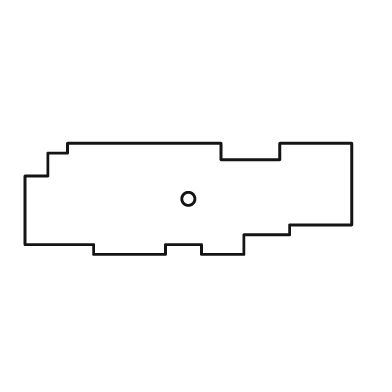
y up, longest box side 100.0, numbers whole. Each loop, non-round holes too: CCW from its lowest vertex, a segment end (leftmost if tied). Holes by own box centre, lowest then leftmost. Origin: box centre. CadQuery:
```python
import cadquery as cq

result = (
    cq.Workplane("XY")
    .moveTo(-29.0, -17.0)
    .lineTo(-7.0, -17.0)
    .lineTo(-7.0, -14.0)
    .lineTo(4.0, -14.0)
    .lineTo(4.0, -17.0)
    .lineTo(17.0, -17.0)
    .lineTo(17.0, -11.0)
    .lineTo(31.0, -11.0)
    .lineTo(31.0, -8.0)
    .lineTo(50.0, -8.0)
    .lineTo(50.0, 17.0)
    .lineTo(28.0, 17.0)
    .lineTo(28.0, 12.0)
    .lineTo(10.0, 12.0)
    .lineTo(10.0, 17.0)
    .lineTo(-37.0, 17.0)
    .lineTo(-37.0, 14.0)
    .lineTo(-43.0, 14.0)
    .lineTo(-43.0, 7.0)
    .lineTo(-50.0, 7.0)
    .lineTo(-50.0, -14.0)
    .lineTo(-29.0, -14.0)
    .close()
    .moveTo(0.0, 0.0)
    .circle(2.0)
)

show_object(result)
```